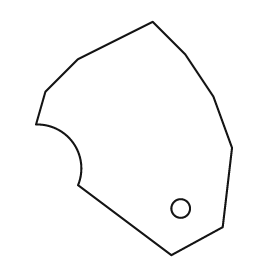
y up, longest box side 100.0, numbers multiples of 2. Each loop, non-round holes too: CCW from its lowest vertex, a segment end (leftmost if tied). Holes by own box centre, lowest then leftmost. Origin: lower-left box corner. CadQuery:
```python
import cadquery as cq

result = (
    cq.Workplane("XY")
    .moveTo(58.0, 0.0)
    .lineTo(80.0, 12.0)
    .lineTo(84.0, 46.0)
    .lineTo(76.0, 68.0)
    .lineTo(64.0, 86.0)
    .lineTo(50.0, 100.0)
    .lineTo(18.0, 84.0)
    .lineTo(4.0, 70.0)
    .lineTo(0.0, 56.0)
    .threePointArc((16.0, 48.0), (18.0, 30.0))
    .close()
    .moveTo(62.0, 20.0)
    .circle(4.0)
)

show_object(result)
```